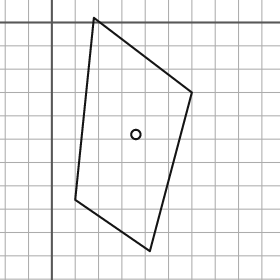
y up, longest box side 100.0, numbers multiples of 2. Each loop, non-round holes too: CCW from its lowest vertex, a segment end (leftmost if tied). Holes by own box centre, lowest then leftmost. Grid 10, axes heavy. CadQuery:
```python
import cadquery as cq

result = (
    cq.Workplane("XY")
    .moveTo(42.0, -98.0)
    .lineTo(60.0, -30.0)
    .lineTo(18.0, 2.0)
    .lineTo(10.0, -76.0)
    .close()
    .moveTo(36.0, -48.0)
    .circle(2.0)
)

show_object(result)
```